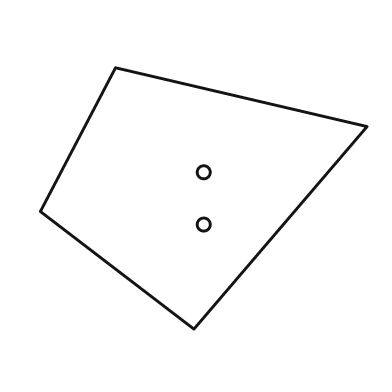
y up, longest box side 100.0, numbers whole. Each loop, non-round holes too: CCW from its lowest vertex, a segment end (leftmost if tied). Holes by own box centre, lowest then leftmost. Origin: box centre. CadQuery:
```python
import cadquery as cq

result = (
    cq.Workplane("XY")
    .moveTo(-3.0, -40.0)
    .lineTo(50.0, 22.0)
    .lineTo(-27.0, 40.0)
    .lineTo(-50.0, -4.0)
    .close()
    .moveTo(0.0, -8.0)
    .circle(2.0)
    .moveTo(0.0, 8.0)
    .circle(2.0)
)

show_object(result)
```